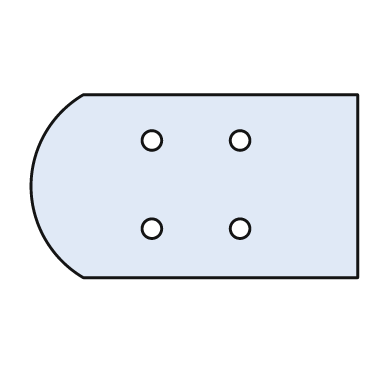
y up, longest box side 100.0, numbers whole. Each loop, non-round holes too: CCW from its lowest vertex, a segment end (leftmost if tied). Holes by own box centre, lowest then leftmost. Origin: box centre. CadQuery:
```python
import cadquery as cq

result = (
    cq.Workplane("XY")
    .moveTo(-34.0, -28.0)
    .lineTo(50.0, -28.0)
    .lineTo(50.0, 28.0)
    .lineTo(-34.0, 28.0)
    .threePointArc((-50.0, 0.0), (-34.0, -28.0))
    .close()
    .moveTo(-13.0, -13.0)
    .circle(3.0)
    .moveTo(14.0, -13.0)
    .circle(3.0)
    .moveTo(-13.0, 14.0)
    .circle(3.0)
    .moveTo(14.0, 14.0)
    .circle(3.0)
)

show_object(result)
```